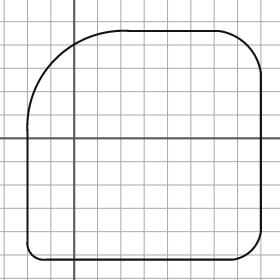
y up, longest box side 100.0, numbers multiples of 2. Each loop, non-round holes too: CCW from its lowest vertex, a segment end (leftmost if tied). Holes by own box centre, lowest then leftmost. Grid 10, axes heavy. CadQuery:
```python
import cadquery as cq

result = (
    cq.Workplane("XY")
    .moveTo(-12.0, -52.0)
    .lineTo(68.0, -52.0)
    .threePointArc((76.0, -48.0), (80.0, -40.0))
    .lineTo(80.0, 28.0)
    .threePointArc((74.0, 40.0), (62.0, 46.0))
    .lineTo(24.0, 46.0)
    .threePointArc((-8.0, 34.0), (-20.0, 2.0))
    .lineTo(-20.0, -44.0)
    .threePointArc((-18.0, -50.0), (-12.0, -52.0))
    .close()
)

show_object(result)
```